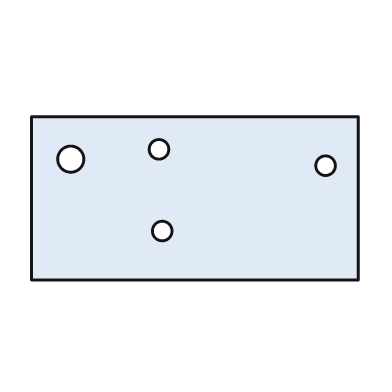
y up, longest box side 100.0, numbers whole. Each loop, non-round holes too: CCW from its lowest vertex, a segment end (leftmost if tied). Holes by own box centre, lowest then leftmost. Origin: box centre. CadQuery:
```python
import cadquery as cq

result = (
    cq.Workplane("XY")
    .moveTo(-50.0, -25.0)
    .lineTo(50.0, -25.0)
    .lineTo(50.0, 25.0)
    .lineTo(-50.0, 25.0)
    .close()
    .moveTo(-10.0, -10.0)
    .circle(3.0)
    .moveTo(40.0, 10.0)
    .circle(3.0)
    .moveTo(-38.0, 12.0)
    .circle(4.0)
    .moveTo(-11.0, 15.0)
    .circle(3.0)
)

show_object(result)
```